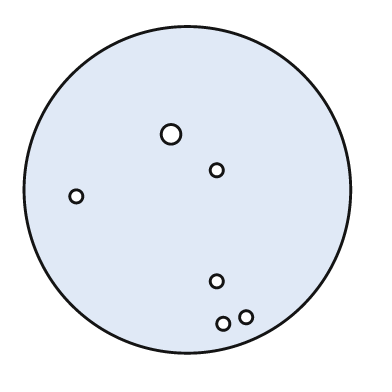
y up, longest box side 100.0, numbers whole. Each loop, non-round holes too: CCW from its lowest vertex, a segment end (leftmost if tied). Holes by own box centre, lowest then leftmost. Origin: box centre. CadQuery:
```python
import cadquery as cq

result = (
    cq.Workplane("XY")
    .moveTo(0.0, 0.0)
    .circle(50.0)
    .moveTo(11.0, -41.0)
    .circle(2.0)
    .moveTo(18.0, -39.0)
    .circle(2.0)
    .moveTo(9.0, -28.0)
    .circle(2.0)
    .moveTo(-34.0, -2.0)
    .circle(2.0)
    .moveTo(9.0, 6.0)
    .circle(2.0)
    .moveTo(-5.0, 17.0)
    .circle(3.0)
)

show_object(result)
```